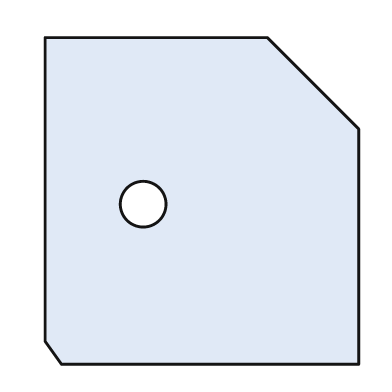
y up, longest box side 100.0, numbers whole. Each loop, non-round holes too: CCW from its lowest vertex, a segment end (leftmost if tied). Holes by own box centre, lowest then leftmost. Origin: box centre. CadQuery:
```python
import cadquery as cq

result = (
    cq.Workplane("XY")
    .moveTo(-43.0, -50.0)
    .lineTo(48.0, -50.0)
    .lineTo(48.0, 22.0)
    .lineTo(20.0, 50.0)
    .lineTo(-48.0, 50.0)
    .lineTo(-48.0, -43.0)
    .close()
    .moveTo(-18.0, -1.0)
    .circle(7.0)
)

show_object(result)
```